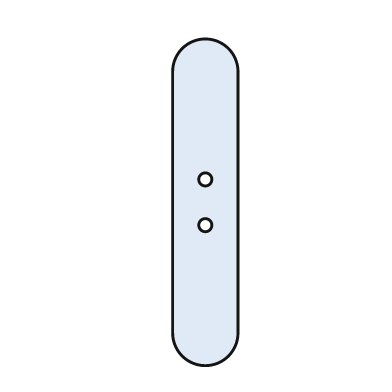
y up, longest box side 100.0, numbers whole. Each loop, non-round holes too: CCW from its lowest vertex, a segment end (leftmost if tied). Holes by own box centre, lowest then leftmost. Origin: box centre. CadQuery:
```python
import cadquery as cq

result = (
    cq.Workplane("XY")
    .moveTo(-10.0, -40.0)
    .threePointArc((0.0, -50.0), (10.0, -40.0))
    .lineTo(10.0, 40.0)
    .threePointArc((0.0, 50.0), (-10.0, 40.0))
    .close()
    .moveTo(0.0, -7.0)
    .circle(2.0)
    .moveTo(0.0, 7.0)
    .circle(2.0)
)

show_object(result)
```